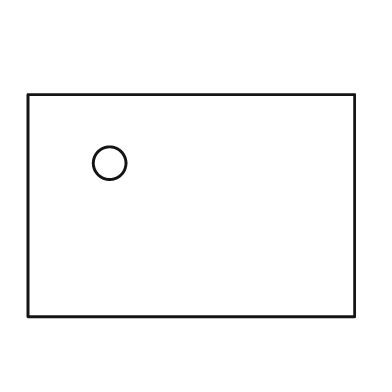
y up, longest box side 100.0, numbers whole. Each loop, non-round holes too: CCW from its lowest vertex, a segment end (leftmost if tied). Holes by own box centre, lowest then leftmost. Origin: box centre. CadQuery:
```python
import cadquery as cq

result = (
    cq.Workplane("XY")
    .moveTo(-50.0, -34.0)
    .lineTo(50.0, -34.0)
    .lineTo(50.0, 34.0)
    .lineTo(-50.0, 34.0)
    .close()
    .moveTo(-25.0, 13.0)
    .circle(5.0)
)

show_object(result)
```